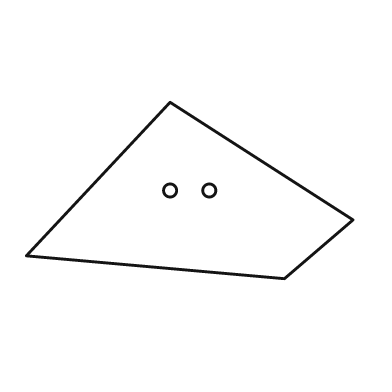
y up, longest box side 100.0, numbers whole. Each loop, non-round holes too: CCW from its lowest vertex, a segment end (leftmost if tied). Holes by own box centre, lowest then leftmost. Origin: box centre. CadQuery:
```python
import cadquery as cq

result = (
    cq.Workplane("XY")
    .moveTo(29.0, -27.0)
    .lineTo(50.0, -9.0)
    .lineTo(-6.0, 27.0)
    .lineTo(-50.0, -20.0)
    .close()
    .moveTo(-6.0, 0.0)
    .circle(2.0)
    .moveTo(6.0, 0.0)
    .circle(2.0)
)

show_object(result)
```